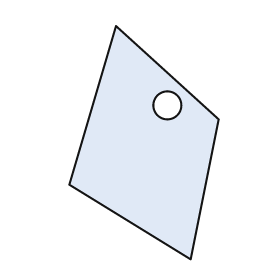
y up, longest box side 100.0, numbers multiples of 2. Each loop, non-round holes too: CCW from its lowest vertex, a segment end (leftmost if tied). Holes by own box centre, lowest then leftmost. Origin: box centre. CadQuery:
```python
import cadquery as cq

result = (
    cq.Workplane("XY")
    .moveTo(20.0, -50.0)
    .lineTo(32.0, 10.0)
    .lineTo(-12.0, 50.0)
    .lineTo(-32.0, -18.0)
    .close()
    .moveTo(10.0, 16.0)
    .circle(6.0)
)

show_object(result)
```